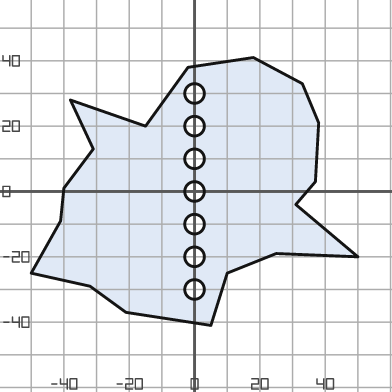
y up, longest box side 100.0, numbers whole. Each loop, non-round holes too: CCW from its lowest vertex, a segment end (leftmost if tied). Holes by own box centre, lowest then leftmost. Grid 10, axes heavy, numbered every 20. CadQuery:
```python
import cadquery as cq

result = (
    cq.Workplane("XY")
    .moveTo(5.0, -41.0)
    .lineTo(10.0, -25.0)
    .lineTo(25.0, -19.0)
    .lineTo(50.0, -20.0)
    .lineTo(31.0, -4.0)
    .lineTo(37.0, 3.0)
    .lineTo(38.0, 21.0)
    .lineTo(33.0, 33.0)
    .lineTo(18.0, 41.0)
    .lineTo(-2.0, 38.0)
    .lineTo(-15.0, 20.0)
    .lineTo(-38.0, 28.0)
    .lineTo(-31.0, 13.0)
    .lineTo(-40.0, 1.0)
    .lineTo(-41.0, -9.0)
    .lineTo(-50.0, -25.0)
    .lineTo(-32.0, -29.0)
    .lineTo(-21.0, -37.0)
    .close()
    .moveTo(0.0, -30.0)
    .circle(3.0)
    .moveTo(0.0, -20.0)
    .circle(3.0)
    .moveTo(0.0, -10.0)
    .circle(3.0)
    .moveTo(0.0, 0.0)
    .circle(3.0)
    .moveTo(0.0, 10.0)
    .circle(3.0)
    .moveTo(0.0, 20.0)
    .circle(3.0)
    .moveTo(0.0, 30.0)
    .circle(3.0)
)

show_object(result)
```